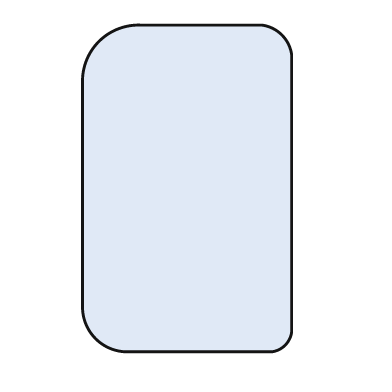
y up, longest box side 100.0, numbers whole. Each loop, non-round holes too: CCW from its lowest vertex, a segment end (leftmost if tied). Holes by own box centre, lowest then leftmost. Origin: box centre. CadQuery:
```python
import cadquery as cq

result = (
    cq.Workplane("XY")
    .moveTo(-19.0, -50.0)
    .lineTo(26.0, -50.0)
    .threePointArc((30.0, -48.0), (32.0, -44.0))
    .lineTo(32.0, 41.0)
    .threePointArc((29.0, 47.0), (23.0, 50.0))
    .lineTo(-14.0, 50.0)
    .threePointArc((-27.0, 45.0), (-32.0, 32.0))
    .lineTo(-32.0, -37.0)
    .threePointArc((-28.0, -46.0), (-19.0, -50.0))
    .close()
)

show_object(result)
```